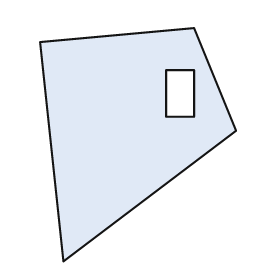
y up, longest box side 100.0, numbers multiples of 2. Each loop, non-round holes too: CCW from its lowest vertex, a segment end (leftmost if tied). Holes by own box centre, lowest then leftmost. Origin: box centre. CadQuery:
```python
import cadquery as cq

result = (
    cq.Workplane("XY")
    .moveTo(-32.0, -50.0)
    .lineTo(42.0, 6.0)
    .lineTo(24.0, 50.0)
    .lineTo(-42.0, 44.0)
    .close()
    .moveTo(12.0, 12.0)
    .lineTo(24.0, 12.0)
    .lineTo(24.0, 32.0)
    .lineTo(12.0, 32.0)
    .close()
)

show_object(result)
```